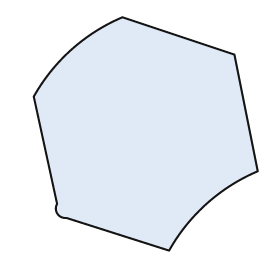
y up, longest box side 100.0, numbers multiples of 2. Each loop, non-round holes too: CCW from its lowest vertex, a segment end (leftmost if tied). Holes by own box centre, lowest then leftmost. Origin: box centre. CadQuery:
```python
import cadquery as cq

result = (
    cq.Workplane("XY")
    .moveTo(10.0, -50.0)
    .threePointArc((26.0, -30.0), (48.0, -16.0))
    .lineTo(38.0, 34.0)
    .lineTo(-10.0, 50.0)
    .threePointArc((-32.0, 36.0), (-48.0, 16.0))
    .lineTo(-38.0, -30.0)
    .threePointArc((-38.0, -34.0), (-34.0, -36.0))
    .close()
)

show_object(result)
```